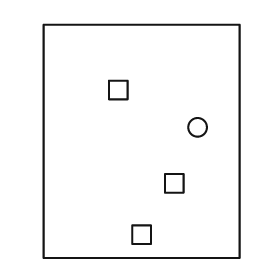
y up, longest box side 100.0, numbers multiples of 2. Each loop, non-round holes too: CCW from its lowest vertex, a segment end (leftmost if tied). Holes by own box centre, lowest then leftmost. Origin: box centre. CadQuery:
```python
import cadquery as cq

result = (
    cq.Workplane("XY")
    .moveTo(-42.0, -50.0)
    .lineTo(42.0, -50.0)
    .lineTo(42.0, 50.0)
    .lineTo(-42.0, 50.0)
    .close()
    .moveTo(-4.0, -44.0)
    .lineTo(4.0, -44.0)
    .lineTo(4.0, -36.0)
    .lineTo(-4.0, -36.0)
    .close()
    .moveTo(10.0, -22.0)
    .lineTo(18.0, -22.0)
    .lineTo(18.0, -14.0)
    .lineTo(10.0, -14.0)
    .close()
    .moveTo(24.0, 6.0)
    .circle(4.0)
    .moveTo(-14.0, 18.0)
    .lineTo(-6.0, 18.0)
    .lineTo(-6.0, 26.0)
    .lineTo(-14.0, 26.0)
    .close()
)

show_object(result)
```